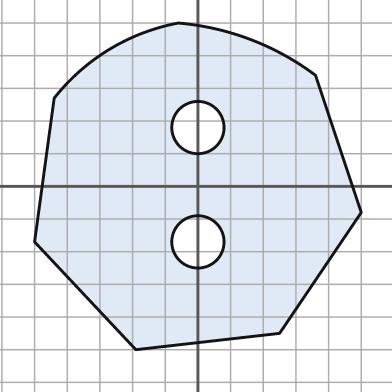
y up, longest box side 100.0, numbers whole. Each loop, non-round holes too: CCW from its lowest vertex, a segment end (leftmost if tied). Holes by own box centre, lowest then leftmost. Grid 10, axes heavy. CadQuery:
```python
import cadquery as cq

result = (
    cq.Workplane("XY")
    .moveTo(-19.0, -50.0)
    .lineTo(25.0, -45.0)
    .lineTo(50.0, -8.0)
    .lineTo(36.0, 34.0)
    .threePointArc((16.0, 45.0), (-6.0, 50.0))
    .threePointArc((-27.0, 42.0), (-44.0, 27.0))
    .lineTo(-50.0, -17.0)
    .close()
    .moveTo(0.0, -17.0)
    .circle(8.0)
    .moveTo(0.0, 18.0)
    .circle(8.0)
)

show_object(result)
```